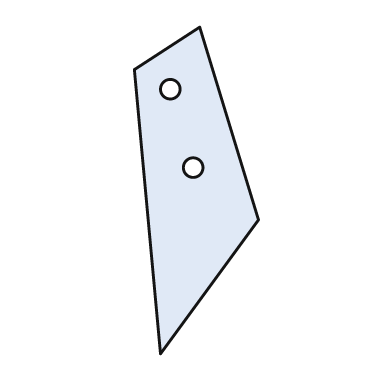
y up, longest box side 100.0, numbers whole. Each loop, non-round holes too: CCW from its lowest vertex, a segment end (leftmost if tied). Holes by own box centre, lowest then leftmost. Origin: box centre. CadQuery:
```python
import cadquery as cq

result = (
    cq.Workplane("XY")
    .moveTo(-11.0, -50.0)
    .lineTo(19.0, -9.0)
    .lineTo(1.0, 50.0)
    .lineTo(-19.0, 37.0)
    .close()
    .moveTo(-1.0, 7.0)
    .circle(3.0)
    .moveTo(-8.0, 31.0)
    .circle(3.0)
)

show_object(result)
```